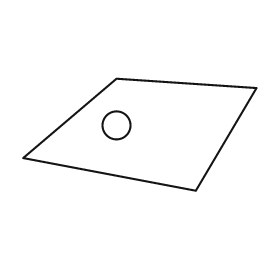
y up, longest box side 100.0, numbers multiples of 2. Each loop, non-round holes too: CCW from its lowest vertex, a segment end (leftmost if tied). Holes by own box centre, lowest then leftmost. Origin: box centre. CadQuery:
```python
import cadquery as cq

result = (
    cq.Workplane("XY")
    .moveTo(24.0, -24.0)
    .lineTo(50.0, 20.0)
    .lineTo(-10.0, 24.0)
    .lineTo(-50.0, -10.0)
    .close()
    .moveTo(-10.0, 4.0)
    .circle(6.0)
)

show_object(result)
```